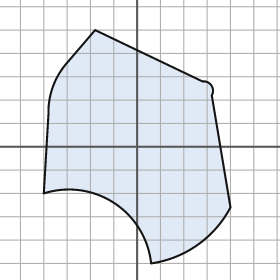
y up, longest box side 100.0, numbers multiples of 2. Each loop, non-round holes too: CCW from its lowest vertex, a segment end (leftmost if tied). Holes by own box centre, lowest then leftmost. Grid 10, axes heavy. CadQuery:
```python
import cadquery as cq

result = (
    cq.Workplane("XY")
    .moveTo(6.0, -50.0)
    .threePointArc((26.0, -42.0), (40.0, -26.0))
    .lineTo(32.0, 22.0)
    .threePointArc((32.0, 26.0), (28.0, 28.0))
    .lineTo(-18.0, 50.0)
    .lineTo(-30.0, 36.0)
    .threePointArc((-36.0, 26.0), (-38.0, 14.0))
    .lineTo(-40.0, -20.0)
    .threePointArc((-10.0, -24.0), (6.0, -50.0))
    .close()
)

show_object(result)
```